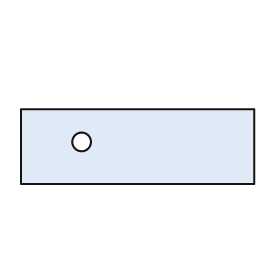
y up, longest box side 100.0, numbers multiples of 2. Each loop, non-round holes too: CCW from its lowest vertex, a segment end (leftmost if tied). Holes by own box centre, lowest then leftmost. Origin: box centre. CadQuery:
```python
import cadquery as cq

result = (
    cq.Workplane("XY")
    .moveTo(-50.0, -16.0)
    .lineTo(50.0, -16.0)
    .lineTo(50.0, 16.0)
    .lineTo(-50.0, 16.0)
    .close()
    .moveTo(-24.0, 2.0)
    .circle(4.0)
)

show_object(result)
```